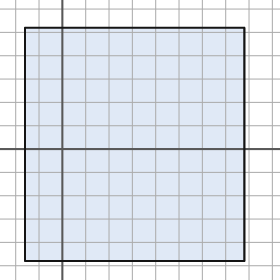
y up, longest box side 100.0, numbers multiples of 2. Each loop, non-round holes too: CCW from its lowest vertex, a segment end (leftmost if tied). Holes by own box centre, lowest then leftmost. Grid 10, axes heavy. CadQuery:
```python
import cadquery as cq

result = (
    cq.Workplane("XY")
    .moveTo(-16.0, -48.0)
    .lineTo(78.0, -48.0)
    .lineTo(78.0, 52.0)
    .lineTo(-16.0, 52.0)
    .close()
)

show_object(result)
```